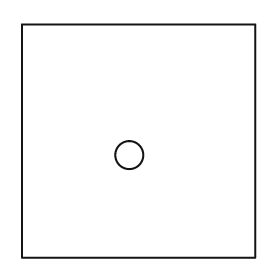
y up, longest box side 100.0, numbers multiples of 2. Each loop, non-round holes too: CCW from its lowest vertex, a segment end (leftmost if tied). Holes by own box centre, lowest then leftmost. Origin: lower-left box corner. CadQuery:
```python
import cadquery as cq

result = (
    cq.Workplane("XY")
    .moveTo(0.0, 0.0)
    .lineTo(100.0, 0.0)
    .lineTo(100.0, 100.0)
    .lineTo(0.0, 100.0)
    .close()
    .moveTo(46.0, 44.0)
    .circle(6.0)
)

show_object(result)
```